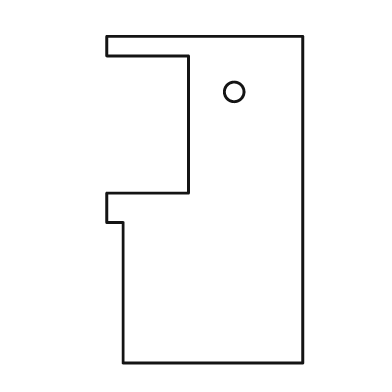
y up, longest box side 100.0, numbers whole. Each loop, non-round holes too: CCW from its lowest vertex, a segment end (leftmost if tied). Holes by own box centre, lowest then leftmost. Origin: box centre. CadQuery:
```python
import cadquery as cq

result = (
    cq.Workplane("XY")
    .moveTo(-25.0, -50.0)
    .lineTo(30.0, -50.0)
    .lineTo(30.0, 50.0)
    .lineTo(-30.0, 50.0)
    .lineTo(-30.0, 44.0)
    .lineTo(-5.0, 44.0)
    .lineTo(-5.0, 2.0)
    .lineTo(-30.0, 2.0)
    .lineTo(-30.0, -7.0)
    .lineTo(-25.0, -7.0)
    .close()
    .moveTo(9.0, 33.0)
    .circle(3.0)
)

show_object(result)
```